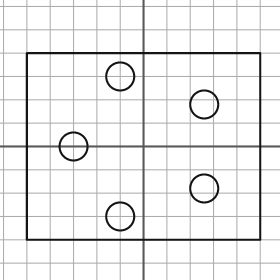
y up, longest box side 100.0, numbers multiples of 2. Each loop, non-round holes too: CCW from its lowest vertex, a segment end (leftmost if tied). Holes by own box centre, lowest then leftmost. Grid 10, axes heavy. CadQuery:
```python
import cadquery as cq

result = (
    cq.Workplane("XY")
    .moveTo(-50.0, -40.0)
    .lineTo(50.0, -40.0)
    .lineTo(50.0, 40.0)
    .lineTo(-50.0, 40.0)
    .close()
    .moveTo(-10.0, -30.0)
    .circle(6.0)
    .moveTo(26.0, -18.0)
    .circle(6.0)
    .moveTo(-30.0, 0.0)
    .circle(6.0)
    .moveTo(26.0, 18.0)
    .circle(6.0)
    .moveTo(-10.0, 30.0)
    .circle(6.0)
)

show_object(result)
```